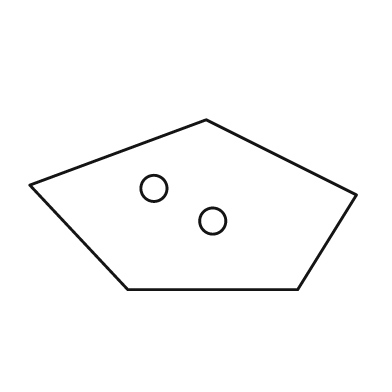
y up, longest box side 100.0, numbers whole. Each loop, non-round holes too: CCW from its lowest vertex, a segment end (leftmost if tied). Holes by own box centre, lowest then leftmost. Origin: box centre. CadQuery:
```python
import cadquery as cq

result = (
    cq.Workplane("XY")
    .moveTo(-20.0, -26.0)
    .lineTo(32.0, -26.0)
    .lineTo(50.0, 3.0)
    .lineTo(4.0, 26.0)
    .lineTo(-50.0, 6.0)
    .close()
    .moveTo(6.0, -5.0)
    .circle(4.0)
    .moveTo(-12.0, 5.0)
    .circle(4.0)
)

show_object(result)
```